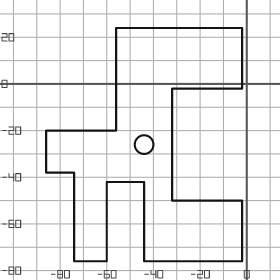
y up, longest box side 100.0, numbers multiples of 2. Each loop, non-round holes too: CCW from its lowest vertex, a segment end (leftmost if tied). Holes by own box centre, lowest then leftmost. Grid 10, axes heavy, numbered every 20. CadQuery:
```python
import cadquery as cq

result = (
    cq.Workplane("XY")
    .moveTo(-74.0, -76.0)
    .lineTo(-60.0, -76.0)
    .lineTo(-60.0, -42.0)
    .lineTo(-44.0, -42.0)
    .lineTo(-44.0, -76.0)
    .lineTo(-2.0, -76.0)
    .lineTo(-2.0, -50.0)
    .lineTo(-32.0, -50.0)
    .lineTo(-32.0, -2.0)
    .lineTo(-2.0, -2.0)
    .lineTo(-2.0, 24.0)
    .lineTo(-56.0, 24.0)
    .lineTo(-56.0, -20.0)
    .lineTo(-86.0, -20.0)
    .lineTo(-86.0, -38.0)
    .lineTo(-74.0, -38.0)
    .close()
    .moveTo(-44.0, -26.0)
    .circle(4.0)
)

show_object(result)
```